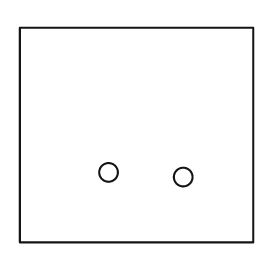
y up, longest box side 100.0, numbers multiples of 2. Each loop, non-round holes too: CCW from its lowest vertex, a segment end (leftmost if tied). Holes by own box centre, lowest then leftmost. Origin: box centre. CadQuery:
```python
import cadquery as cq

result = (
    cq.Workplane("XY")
    .moveTo(-50.0, -46.0)
    .lineTo(50.0, -46.0)
    .lineTo(50.0, 46.0)
    .lineTo(-50.0, 46.0)
    .close()
    .moveTo(20.0, -18.0)
    .circle(4.0)
    .moveTo(-12.0, -16.0)
    .circle(4.0)
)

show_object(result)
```